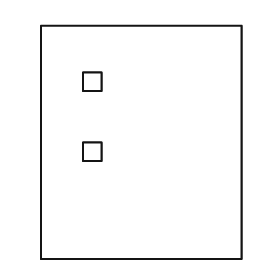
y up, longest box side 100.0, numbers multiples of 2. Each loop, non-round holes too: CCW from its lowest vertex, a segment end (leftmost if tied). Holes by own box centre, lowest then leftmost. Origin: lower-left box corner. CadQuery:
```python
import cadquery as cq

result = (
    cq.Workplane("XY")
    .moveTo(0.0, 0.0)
    .lineTo(86.0, 0.0)
    .lineTo(86.0, 100.0)
    .lineTo(0.0, 100.0)
    .close()
    .moveTo(18.0, 42.0)
    .lineTo(26.0, 42.0)
    .lineTo(26.0, 50.0)
    .lineTo(18.0, 50.0)
    .close()
    .moveTo(18.0, 72.0)
    .lineTo(26.0, 72.0)
    .lineTo(26.0, 80.0)
    .lineTo(18.0, 80.0)
    .close()
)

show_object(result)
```